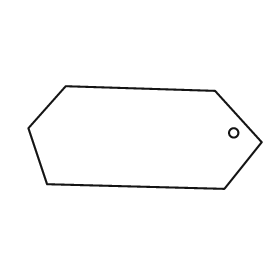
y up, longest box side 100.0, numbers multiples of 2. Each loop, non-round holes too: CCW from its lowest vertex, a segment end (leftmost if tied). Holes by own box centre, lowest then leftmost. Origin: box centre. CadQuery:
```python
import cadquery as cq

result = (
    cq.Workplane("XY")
    .moveTo(34.0, -22.0)
    .lineTo(50.0, -2.0)
    .lineTo(30.0, 20.0)
    .lineTo(-34.0, 22.0)
    .lineTo(-50.0, 4.0)
    .lineTo(-42.0, -20.0)
    .close()
    .moveTo(38.0, 2.0)
    .circle(2.0)
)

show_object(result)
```